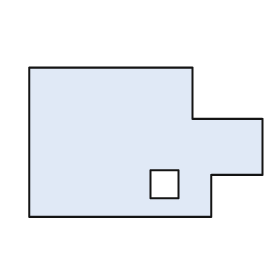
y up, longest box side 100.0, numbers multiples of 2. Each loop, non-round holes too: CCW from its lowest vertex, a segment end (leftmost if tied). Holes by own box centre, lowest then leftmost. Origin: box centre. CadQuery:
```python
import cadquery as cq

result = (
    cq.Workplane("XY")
    .moveTo(-50.0, -32.0)
    .lineTo(28.0, -32.0)
    .lineTo(28.0, -14.0)
    .lineTo(50.0, -14.0)
    .lineTo(50.0, 10.0)
    .lineTo(20.0, 10.0)
    .lineTo(20.0, 32.0)
    .lineTo(-50.0, 32.0)
    .close()
    .moveTo(2.0, -24.0)
    .lineTo(14.0, -24.0)
    .lineTo(14.0, -12.0)
    .lineTo(2.0, -12.0)
    .close()
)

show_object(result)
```